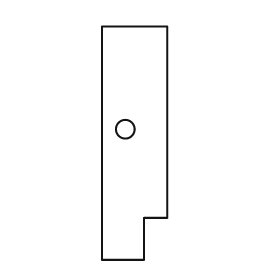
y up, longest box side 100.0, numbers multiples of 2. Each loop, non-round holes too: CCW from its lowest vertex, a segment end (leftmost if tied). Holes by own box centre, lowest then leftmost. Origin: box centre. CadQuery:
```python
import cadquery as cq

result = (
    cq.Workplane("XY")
    .moveTo(-14.0, -50.0)
    .lineTo(4.0, -50.0)
    .lineTo(4.0, -32.0)
    .lineTo(14.0, -32.0)
    .lineTo(14.0, 50.0)
    .lineTo(-14.0, 50.0)
    .close()
    .moveTo(-4.0, 6.0)
    .circle(4.0)
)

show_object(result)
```